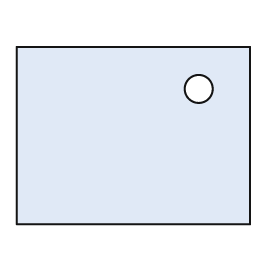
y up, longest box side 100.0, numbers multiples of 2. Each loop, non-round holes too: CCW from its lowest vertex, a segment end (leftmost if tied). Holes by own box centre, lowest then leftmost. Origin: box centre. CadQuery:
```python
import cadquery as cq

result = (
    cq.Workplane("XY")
    .moveTo(-50.0, -38.0)
    .lineTo(50.0, -38.0)
    .lineTo(50.0, 38.0)
    .lineTo(-50.0, 38.0)
    .close()
    .moveTo(28.0, 20.0)
    .circle(6.0)
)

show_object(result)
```